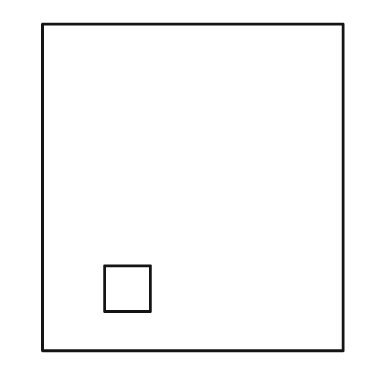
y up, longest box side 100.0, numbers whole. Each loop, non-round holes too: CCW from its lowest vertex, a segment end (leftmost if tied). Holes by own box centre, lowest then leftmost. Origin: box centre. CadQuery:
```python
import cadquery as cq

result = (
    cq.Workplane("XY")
    .moveTo(-46.0, -50.0)
    .lineTo(46.0, -50.0)
    .lineTo(46.0, 50.0)
    .lineTo(-46.0, 50.0)
    .close()
    .moveTo(-27.0, -38.0)
    .lineTo(-13.0, -38.0)
    .lineTo(-13.0, -24.0)
    .lineTo(-27.0, -24.0)
    .close()
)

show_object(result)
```